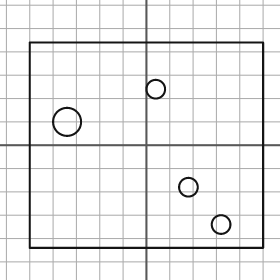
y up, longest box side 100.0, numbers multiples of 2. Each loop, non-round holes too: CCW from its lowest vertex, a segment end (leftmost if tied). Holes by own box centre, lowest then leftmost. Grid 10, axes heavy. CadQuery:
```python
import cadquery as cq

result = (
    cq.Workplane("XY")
    .moveTo(-50.0, -44.0)
    .lineTo(50.0, -44.0)
    .lineTo(50.0, 44.0)
    .lineTo(-50.0, 44.0)
    .close()
    .moveTo(32.0, -34.0)
    .circle(4.0)
    .moveTo(18.0, -18.0)
    .circle(4.0)
    .moveTo(-34.0, 10.0)
    .circle(6.0)
    .moveTo(4.0, 24.0)
    .circle(4.0)
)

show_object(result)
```